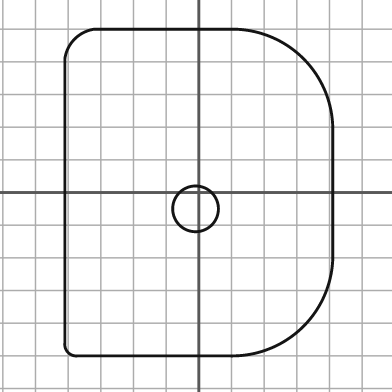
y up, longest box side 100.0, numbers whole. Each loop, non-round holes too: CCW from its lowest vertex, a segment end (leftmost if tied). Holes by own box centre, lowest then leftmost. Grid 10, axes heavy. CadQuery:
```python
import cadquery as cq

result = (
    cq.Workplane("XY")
    .moveTo(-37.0, -50.0)
    .lineTo(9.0, -50.0)
    .threePointArc((32.0, -41.0), (41.0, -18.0))
    .lineTo(41.0, 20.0)
    .threePointArc((32.0, 41.0), (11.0, 50.0))
    .lineTo(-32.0, 50.0)
    .threePointArc((-38.0, 47.0), (-41.0, 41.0))
    .lineTo(-41.0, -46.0)
    .threePointArc((-40.0, -49.0), (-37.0, -50.0))
    .close()
    .moveTo(-1.0, -5.0)
    .circle(7.0)
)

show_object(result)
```